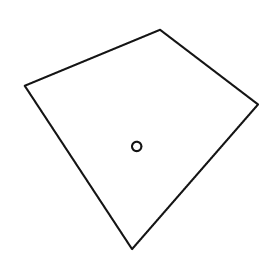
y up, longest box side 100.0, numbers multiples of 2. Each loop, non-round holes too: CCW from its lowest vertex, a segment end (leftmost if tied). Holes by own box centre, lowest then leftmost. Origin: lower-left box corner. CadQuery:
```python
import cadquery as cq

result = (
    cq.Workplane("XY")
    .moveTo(46.0, 0.0)
    .lineTo(100.0, 62.0)
    .lineTo(58.0, 94.0)
    .lineTo(0.0, 70.0)
    .close()
    .moveTo(48.0, 44.0)
    .circle(2.0)
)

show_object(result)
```